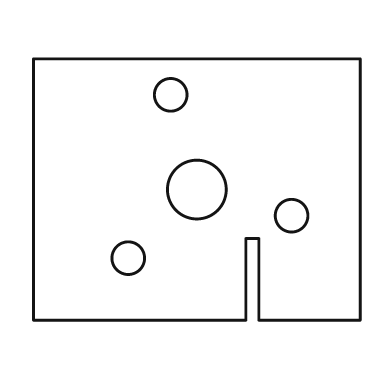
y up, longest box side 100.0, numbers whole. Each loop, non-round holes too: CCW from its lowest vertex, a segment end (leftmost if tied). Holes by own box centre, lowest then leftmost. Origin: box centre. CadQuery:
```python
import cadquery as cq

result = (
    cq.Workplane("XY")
    .moveTo(-50.0, -40.0)
    .lineTo(15.0, -40.0)
    .lineTo(15.0, -15.0)
    .lineTo(19.0, -15.0)
    .lineTo(19.0, -40.0)
    .lineTo(50.0, -40.0)
    .lineTo(50.0, 40.0)
    .lineTo(-50.0, 40.0)
    .close()
    .moveTo(-21.0, -21.0)
    .circle(5.0)
    .moveTo(29.0, -8.0)
    .circle(5.0)
    .moveTo(0.0, 0.0)
    .circle(9.0)
    .moveTo(-8.0, 29.0)
    .circle(5.0)
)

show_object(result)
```